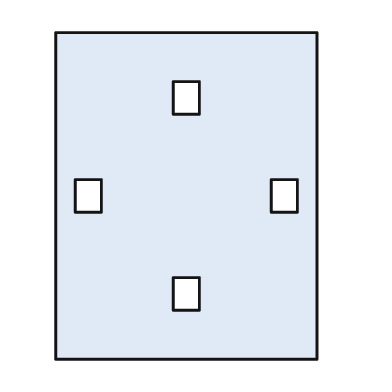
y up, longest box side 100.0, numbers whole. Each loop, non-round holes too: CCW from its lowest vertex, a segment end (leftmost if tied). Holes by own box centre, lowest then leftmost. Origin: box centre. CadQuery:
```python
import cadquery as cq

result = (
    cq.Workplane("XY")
    .moveTo(-40.0, -50.0)
    .lineTo(40.0, -50.0)
    .lineTo(40.0, 50.0)
    .lineTo(-40.0, 50.0)
    .close()
    .moveTo(-4.0, -35.0)
    .lineTo(4.0, -35.0)
    .lineTo(4.0, -25.0)
    .lineTo(-4.0, -25.0)
    .close()
    .moveTo(-34.0, -5.0)
    .lineTo(-26.0, -5.0)
    .lineTo(-26.0, 5.0)
    .lineTo(-34.0, 5.0)
    .close()
    .moveTo(26.0, -5.0)
    .lineTo(34.0, -5.0)
    .lineTo(34.0, 5.0)
    .lineTo(26.0, 5.0)
    .close()
    .moveTo(-4.0, 25.0)
    .lineTo(4.0, 25.0)
    .lineTo(4.0, 35.0)
    .lineTo(-4.0, 35.0)
    .close()
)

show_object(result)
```